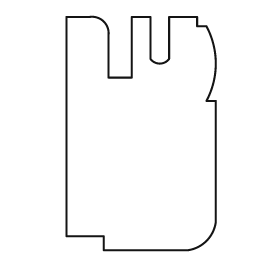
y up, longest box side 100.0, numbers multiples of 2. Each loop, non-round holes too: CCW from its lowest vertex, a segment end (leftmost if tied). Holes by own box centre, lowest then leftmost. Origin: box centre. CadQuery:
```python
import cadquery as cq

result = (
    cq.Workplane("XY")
    .moveTo(-16.0, -50.0)
    .lineTo(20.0, -50.0)
    .threePointArc((28.0, -46.0), (32.0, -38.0))
    .lineTo(32.0, 14.0)
    .lineTo(28.0, 14.0)
    .threePointArc((32.0, 30.0), (28.0, 46.0))
    .lineTo(24.0, 46.0)
    .lineTo(24.0, 50.0)
    .lineTo(12.0, 50.0)
    .lineTo(12.0, 32.0)
    .threePointArc((8.0, 30.0), (4.0, 32.0))
    .lineTo(4.0, 50.0)
    .lineTo(-4.0, 50.0)
    .lineTo(-4.0, 24.0)
    .lineTo(-14.0, 24.0)
    .lineTo(-14.0, 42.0)
    .threePointArc((-16.0, 48.0), (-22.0, 50.0))
    .lineTo(-32.0, 50.0)
    .lineTo(-32.0, -44.0)
    .lineTo(-16.0, -44.0)
    .close()
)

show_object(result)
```